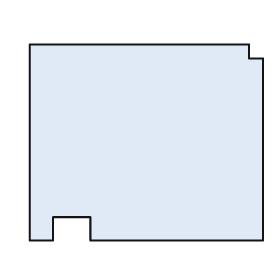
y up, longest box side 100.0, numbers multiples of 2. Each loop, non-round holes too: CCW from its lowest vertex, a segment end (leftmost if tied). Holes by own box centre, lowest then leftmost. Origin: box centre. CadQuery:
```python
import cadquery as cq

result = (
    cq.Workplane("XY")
    .moveTo(-50.0, -42.0)
    .lineTo(-40.0, -42.0)
    .lineTo(-40.0, -32.0)
    .lineTo(-24.0, -32.0)
    .lineTo(-24.0, -42.0)
    .lineTo(50.0, -42.0)
    .lineTo(50.0, 36.0)
    .lineTo(44.0, 36.0)
    .lineTo(44.0, 42.0)
    .lineTo(-50.0, 42.0)
    .close()
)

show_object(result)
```